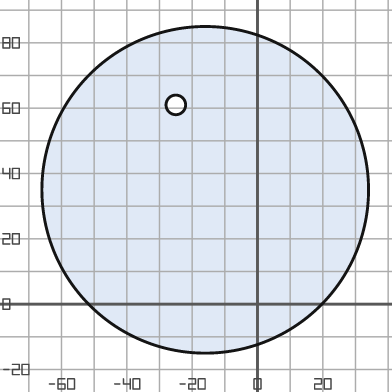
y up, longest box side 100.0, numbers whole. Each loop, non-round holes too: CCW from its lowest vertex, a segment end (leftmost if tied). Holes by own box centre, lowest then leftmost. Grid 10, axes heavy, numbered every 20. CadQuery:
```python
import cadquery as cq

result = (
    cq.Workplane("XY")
    .moveTo(-16.0, 35.0)
    .circle(50.0)
    .moveTo(-25.0, 61.0)
    .circle(3.0)
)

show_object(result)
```